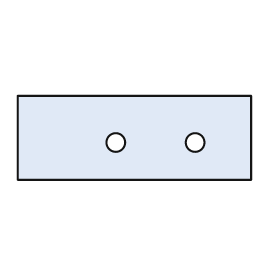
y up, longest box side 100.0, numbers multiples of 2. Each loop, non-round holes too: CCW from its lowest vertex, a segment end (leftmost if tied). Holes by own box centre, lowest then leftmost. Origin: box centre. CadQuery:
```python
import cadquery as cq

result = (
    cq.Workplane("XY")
    .moveTo(-50.0, -18.0)
    .lineTo(50.0, -18.0)
    .lineTo(50.0, 18.0)
    .lineTo(-50.0, 18.0)
    .close()
    .moveTo(-8.0, -2.0)
    .circle(4.0)
    .moveTo(26.0, -2.0)
    .circle(4.0)
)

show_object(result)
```